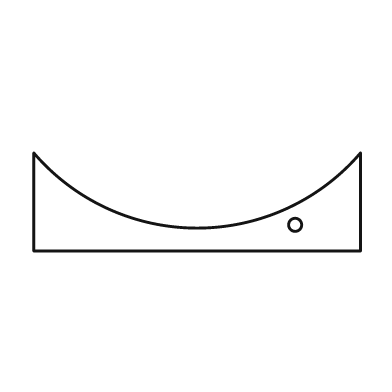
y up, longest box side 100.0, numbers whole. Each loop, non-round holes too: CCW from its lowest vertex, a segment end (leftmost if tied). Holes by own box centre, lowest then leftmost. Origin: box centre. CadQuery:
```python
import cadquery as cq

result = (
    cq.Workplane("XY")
    .moveTo(-50.0, -15.0)
    .lineTo(50.0, -15.0)
    .lineTo(50.0, 15.0)
    .threePointArc((0.0, -8.0), (-50.0, 15.0))
    .close()
    .moveTo(30.0, -7.0)
    .circle(2.0)
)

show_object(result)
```